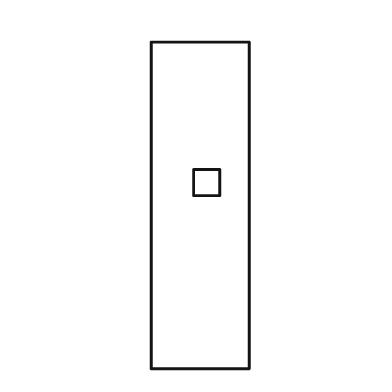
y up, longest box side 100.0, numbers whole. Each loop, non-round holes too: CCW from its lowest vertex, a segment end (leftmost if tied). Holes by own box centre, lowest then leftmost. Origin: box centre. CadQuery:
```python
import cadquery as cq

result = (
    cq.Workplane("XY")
    .moveTo(-15.0, -50.0)
    .lineTo(15.0, -50.0)
    .lineTo(15.0, 50.0)
    .lineTo(-15.0, 50.0)
    .close()
    .moveTo(-2.0, 3.0)
    .lineTo(6.0, 3.0)
    .lineTo(6.0, 11.0)
    .lineTo(-2.0, 11.0)
    .close()
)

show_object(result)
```